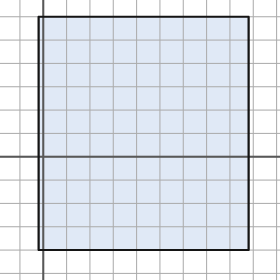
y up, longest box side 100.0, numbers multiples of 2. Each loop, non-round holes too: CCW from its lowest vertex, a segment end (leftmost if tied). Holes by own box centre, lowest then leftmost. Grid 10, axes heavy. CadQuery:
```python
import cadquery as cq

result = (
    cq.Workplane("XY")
    .moveTo(-2.0, -40.0)
    .lineTo(88.0, -40.0)
    .lineTo(88.0, 60.0)
    .lineTo(-2.0, 60.0)
    .close()
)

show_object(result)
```